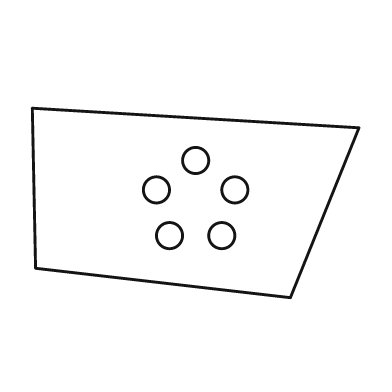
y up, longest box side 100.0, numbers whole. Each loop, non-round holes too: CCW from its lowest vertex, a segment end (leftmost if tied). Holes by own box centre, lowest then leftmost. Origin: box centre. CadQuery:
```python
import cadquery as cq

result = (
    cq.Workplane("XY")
    .moveTo(29.0, -29.0)
    .lineTo(50.0, 23.0)
    .lineTo(-50.0, 29.0)
    .lineTo(-49.0, -20.0)
    .close()
    .moveTo(-8.0, -10.0)
    .circle(4.0)
    .moveTo(8.0, -10.0)
    .circle(4.0)
    .moveTo(-12.0, 4.0)
    .circle(4.0)
    .moveTo(12.0, 4.0)
    .circle(4.0)
    .moveTo(0.0, 13.0)
    .circle(4.0)
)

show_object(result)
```